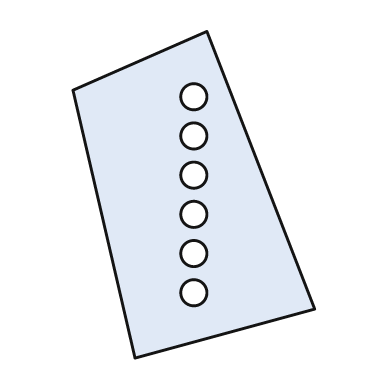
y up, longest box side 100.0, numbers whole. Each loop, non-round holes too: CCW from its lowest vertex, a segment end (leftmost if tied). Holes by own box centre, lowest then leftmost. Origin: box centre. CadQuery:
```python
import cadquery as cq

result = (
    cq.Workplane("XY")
    .moveTo(-18.0, -50.0)
    .lineTo(37.0, -35.0)
    .lineTo(4.0, 50.0)
    .lineTo(-37.0, 32.0)
    .close()
    .moveTo(0.0, -30.0)
    .circle(4.0)
    .moveTo(0.0, -18.0)
    .circle(4.0)
    .moveTo(0.0, -6.0)
    .circle(4.0)
    .moveTo(0.0, 6.0)
    .circle(4.0)
    .moveTo(0.0, 18.0)
    .circle(4.0)
    .moveTo(0.0, 30.0)
    .circle(4.0)
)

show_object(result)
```